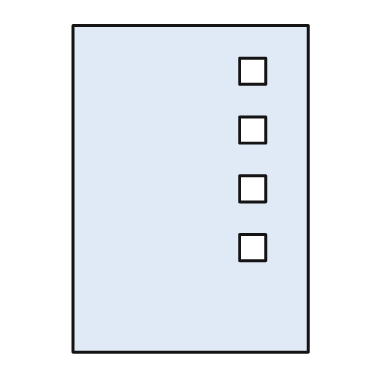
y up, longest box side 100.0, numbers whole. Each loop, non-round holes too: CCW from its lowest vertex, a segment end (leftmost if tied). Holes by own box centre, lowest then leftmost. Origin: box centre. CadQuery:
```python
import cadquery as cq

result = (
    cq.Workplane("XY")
    .moveTo(-36.0, -50.0)
    .lineTo(36.0, -50.0)
    .lineTo(36.0, 50.0)
    .lineTo(-36.0, 50.0)
    .close()
    .moveTo(15.0, -22.0)
    .lineTo(23.0, -22.0)
    .lineTo(23.0, -14.0)
    .lineTo(15.0, -14.0)
    .close()
    .moveTo(15.0, -4.0)
    .lineTo(23.0, -4.0)
    .lineTo(23.0, 4.0)
    .lineTo(15.0, 4.0)
    .close()
    .moveTo(15.0, 14.0)
    .lineTo(23.0, 14.0)
    .lineTo(23.0, 22.0)
    .lineTo(15.0, 22.0)
    .close()
    .moveTo(15.0, 32.0)
    .lineTo(23.0, 32.0)
    .lineTo(23.0, 40.0)
    .lineTo(15.0, 40.0)
    .close()
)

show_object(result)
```